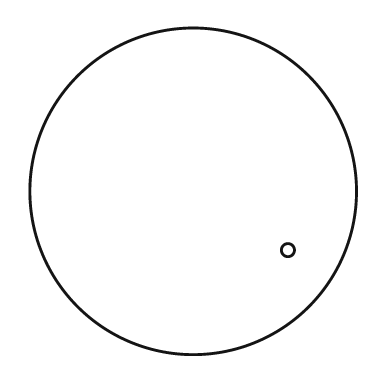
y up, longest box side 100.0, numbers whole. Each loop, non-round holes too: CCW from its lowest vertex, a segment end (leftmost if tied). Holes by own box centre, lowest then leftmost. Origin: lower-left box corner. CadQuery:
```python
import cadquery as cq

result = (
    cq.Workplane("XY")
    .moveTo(50.0, 50.0)
    .circle(50.0)
    .moveTo(79.0, 32.0)
    .circle(2.0)
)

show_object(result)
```